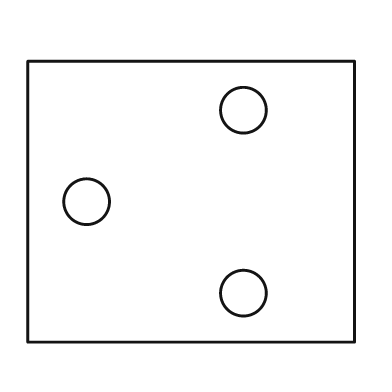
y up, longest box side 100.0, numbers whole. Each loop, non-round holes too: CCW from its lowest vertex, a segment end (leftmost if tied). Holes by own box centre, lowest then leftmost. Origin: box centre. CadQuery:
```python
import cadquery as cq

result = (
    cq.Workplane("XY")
    .moveTo(-50.0, -43.0)
    .lineTo(50.0, -43.0)
    .lineTo(50.0, 43.0)
    .lineTo(-50.0, 43.0)
    .close()
    .moveTo(16.0, -28.0)
    .circle(7.0)
    .moveTo(-32.0, 0.0)
    .circle(7.0)
    .moveTo(16.0, 28.0)
    .circle(7.0)
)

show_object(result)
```